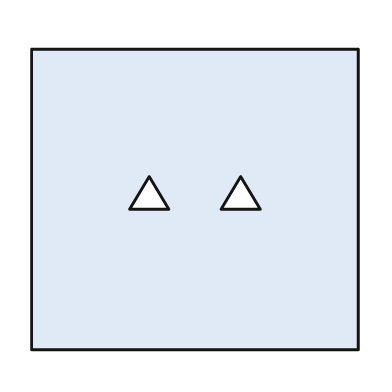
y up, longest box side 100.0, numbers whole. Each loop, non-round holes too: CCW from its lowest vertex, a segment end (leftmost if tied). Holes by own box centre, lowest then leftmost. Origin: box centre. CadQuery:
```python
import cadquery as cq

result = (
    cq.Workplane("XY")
    .moveTo(-50.0, -46.0)
    .lineTo(50.0, -46.0)
    .lineTo(50.0, 46.0)
    .lineTo(-50.0, 46.0)
    .close()
    .moveTo(-20.0, -3.0)
    .lineTo(-8.0, -3.0)
    .lineTo(-14.0, 7.0)
    .close()
    .moveTo(8.0, -3.0)
    .lineTo(20.0, -3.0)
    .lineTo(14.0, 7.0)
    .close()
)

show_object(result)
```